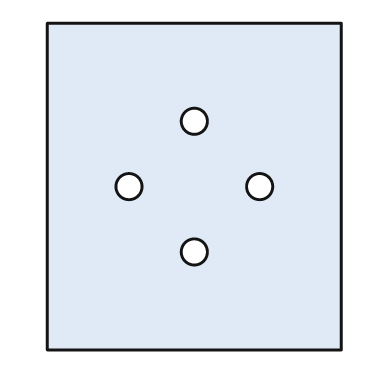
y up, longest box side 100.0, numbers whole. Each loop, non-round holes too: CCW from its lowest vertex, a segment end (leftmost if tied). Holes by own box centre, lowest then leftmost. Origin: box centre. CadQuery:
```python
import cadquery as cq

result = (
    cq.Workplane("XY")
    .moveTo(-45.0, -50.0)
    .lineTo(45.0, -50.0)
    .lineTo(45.0, 50.0)
    .lineTo(-45.0, 50.0)
    .close()
    .moveTo(0.0, -20.0)
    .circle(4.0)
    .moveTo(-20.0, 0.0)
    .circle(4.0)
    .moveTo(20.0, 0.0)
    .circle(4.0)
    .moveTo(0.0, 20.0)
    .circle(4.0)
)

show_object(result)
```